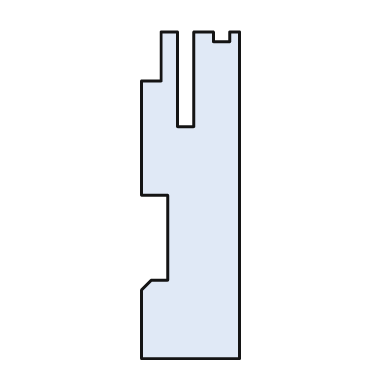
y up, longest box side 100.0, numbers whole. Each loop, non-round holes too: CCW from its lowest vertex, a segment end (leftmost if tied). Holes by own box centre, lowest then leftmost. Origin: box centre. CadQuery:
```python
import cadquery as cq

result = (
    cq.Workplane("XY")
    .moveTo(-15.0, -50.0)
    .lineTo(15.0, -50.0)
    .lineTo(15.0, 50.0)
    .lineTo(12.0, 50.0)
    .lineTo(12.0, 47.0)
    .lineTo(7.0, 47.0)
    .lineTo(7.0, 50.0)
    .lineTo(1.0, 50.0)
    .lineTo(1.0, 21.0)
    .lineTo(-4.0, 21.0)
    .lineTo(-4.0, 50.0)
    .lineTo(-9.0, 50.0)
    .lineTo(-9.0, 35.0)
    .lineTo(-15.0, 35.0)
    .lineTo(-15.0, 0.0)
    .lineTo(-7.0, 0.0)
    .lineTo(-7.0, -26.0)
    .lineTo(-12.0, -26.0)
    .lineTo(-15.0, -29.0)
    .close()
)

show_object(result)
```